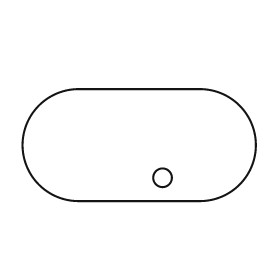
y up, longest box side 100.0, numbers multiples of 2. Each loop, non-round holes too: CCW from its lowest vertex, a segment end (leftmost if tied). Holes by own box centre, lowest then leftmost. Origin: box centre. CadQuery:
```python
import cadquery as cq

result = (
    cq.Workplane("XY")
    .moveTo(-26.0, -24.0)
    .lineTo(26.0, -24.0)
    .threePointArc((50.0, 0.0), (26.0, 24.0))
    .lineTo(-26.0, 24.0)
    .threePointArc((-50.0, 0.0), (-26.0, -24.0))
    .close()
    .moveTo(10.0, -14.0)
    .circle(4.0)
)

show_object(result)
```